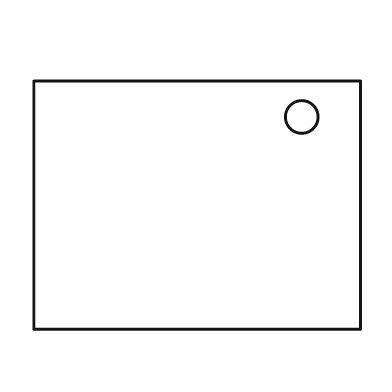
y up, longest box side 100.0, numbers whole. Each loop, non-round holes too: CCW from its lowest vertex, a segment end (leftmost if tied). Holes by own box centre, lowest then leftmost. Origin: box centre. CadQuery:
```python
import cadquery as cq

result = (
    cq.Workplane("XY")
    .moveTo(-50.0, -38.0)
    .lineTo(50.0, -38.0)
    .lineTo(50.0, 38.0)
    .lineTo(-50.0, 38.0)
    .close()
    .moveTo(32.0, 27.0)
    .circle(5.0)
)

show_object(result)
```